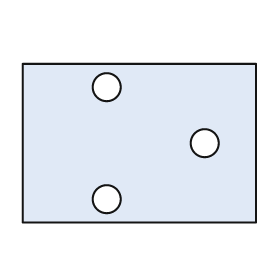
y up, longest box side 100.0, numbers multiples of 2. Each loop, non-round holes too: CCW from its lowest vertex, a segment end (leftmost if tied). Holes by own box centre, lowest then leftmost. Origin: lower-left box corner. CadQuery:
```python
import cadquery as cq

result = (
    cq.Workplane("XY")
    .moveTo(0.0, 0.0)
    .lineTo(100.0, 0.0)
    .lineTo(100.0, 68.0)
    .lineTo(0.0, 68.0)
    .close()
    .moveTo(36.0, 10.0)
    .circle(6.0)
    .moveTo(78.0, 34.0)
    .circle(6.0)
    .moveTo(36.0, 58.0)
    .circle(6.0)
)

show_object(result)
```